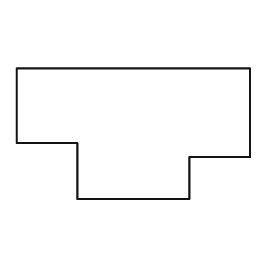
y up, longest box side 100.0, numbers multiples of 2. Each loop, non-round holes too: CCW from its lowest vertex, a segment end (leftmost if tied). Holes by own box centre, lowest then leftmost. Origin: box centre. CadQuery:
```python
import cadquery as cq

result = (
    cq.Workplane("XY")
    .moveTo(-24.0, -28.0)
    .lineTo(24.0, -28.0)
    .lineTo(24.0, -10.0)
    .lineTo(50.0, -10.0)
    .lineTo(50.0, 28.0)
    .lineTo(-50.0, 28.0)
    .lineTo(-50.0, -4.0)
    .lineTo(-24.0, -4.0)
    .close()
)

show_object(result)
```